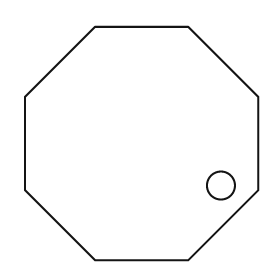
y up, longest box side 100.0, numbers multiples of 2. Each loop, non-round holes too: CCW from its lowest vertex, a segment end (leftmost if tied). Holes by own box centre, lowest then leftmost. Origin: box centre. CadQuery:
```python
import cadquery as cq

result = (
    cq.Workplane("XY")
    .moveTo(-20.0, -50.0)
    .lineTo(20.0, -50.0)
    .lineTo(50.0, -20.0)
    .lineTo(50.0, 20.0)
    .lineTo(20.0, 50.0)
    .lineTo(-20.0, 50.0)
    .lineTo(-50.0, 20.0)
    .lineTo(-50.0, -20.0)
    .close()
    .moveTo(34.0, -18.0)
    .circle(6.0)
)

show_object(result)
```